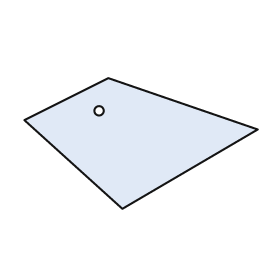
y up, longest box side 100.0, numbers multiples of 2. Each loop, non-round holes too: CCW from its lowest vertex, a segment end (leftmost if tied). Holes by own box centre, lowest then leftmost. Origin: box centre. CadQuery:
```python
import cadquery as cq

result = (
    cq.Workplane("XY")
    .moveTo(-8.0, -28.0)
    .lineTo(50.0, 6.0)
    .lineTo(-14.0, 28.0)
    .lineTo(-50.0, 10.0)
    .close()
    .moveTo(-18.0, 14.0)
    .circle(2.0)
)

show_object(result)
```